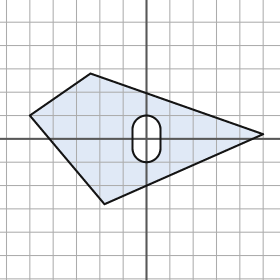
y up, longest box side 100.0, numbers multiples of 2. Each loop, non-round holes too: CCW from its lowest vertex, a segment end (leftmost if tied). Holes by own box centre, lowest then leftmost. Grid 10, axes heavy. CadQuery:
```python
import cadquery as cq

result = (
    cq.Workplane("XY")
    .moveTo(-18.0, -28.0)
    .lineTo(50.0, 2.0)
    .lineTo(-24.0, 28.0)
    .lineTo(-50.0, 10.0)
    .close()
    .moveTo(-6.0, -4.0)
    .threePointArc((0.0, -10.0), (6.0, -4.0))
    .lineTo(6.0, 4.0)
    .threePointArc((0.0, 10.0), (-6.0, 4.0))
    .close()
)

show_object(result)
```